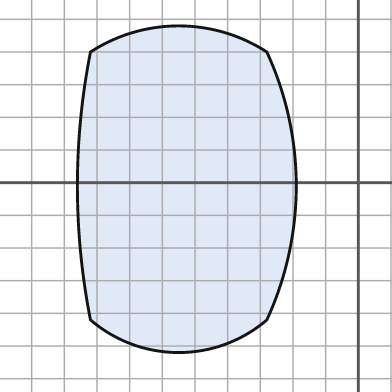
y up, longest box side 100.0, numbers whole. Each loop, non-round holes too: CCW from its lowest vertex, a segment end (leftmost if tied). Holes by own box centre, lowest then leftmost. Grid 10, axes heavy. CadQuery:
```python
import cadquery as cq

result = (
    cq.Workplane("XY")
    .moveTo(-82.0, -42.0)
    .threePointArc((-55.0, -52.0), (-28.0, -42.0))
    .threePointArc((-19.0, -1.0), (-28.0, 40.0))
    .threePointArc((-55.0, 48.0), (-82.0, 40.0))
    .threePointArc((-86.0, -1.0), (-82.0, -42.0))
    .close()
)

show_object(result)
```